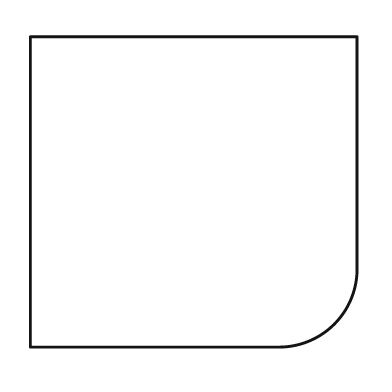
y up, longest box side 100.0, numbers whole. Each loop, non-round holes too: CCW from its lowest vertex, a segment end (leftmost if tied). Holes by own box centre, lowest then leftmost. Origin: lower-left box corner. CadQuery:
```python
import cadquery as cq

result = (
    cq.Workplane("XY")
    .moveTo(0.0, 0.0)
    .lineTo(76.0, 0.0)
    .threePointArc((93.0, 7.0), (100.0, 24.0))
    .lineTo(100.0, 95.0)
    .lineTo(0.0, 95.0)
    .close()
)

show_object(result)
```